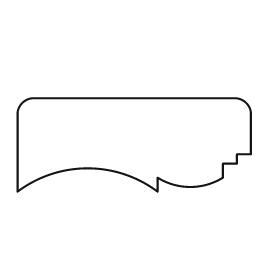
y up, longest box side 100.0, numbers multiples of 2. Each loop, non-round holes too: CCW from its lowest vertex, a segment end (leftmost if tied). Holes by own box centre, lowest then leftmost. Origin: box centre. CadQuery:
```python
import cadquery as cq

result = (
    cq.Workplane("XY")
    .moveTo(-50.0, -20.0)
    .threePointArc((-20.0, -10.0), (10.0, -20.0))
    .lineTo(10.0, -14.0)
    .threePointArc((24.0, -18.0), (38.0, -14.0))
    .lineTo(38.0, -8.0)
    .lineTo(44.0, -8.0)
    .lineTo(44.0, -4.0)
    .lineTo(50.0, -4.0)
    .lineTo(50.0, 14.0)
    .threePointArc((48.0, 18.0), (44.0, 20.0))
    .lineTo(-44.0, 20.0)
    .threePointArc((-48.0, 18.0), (-50.0, 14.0))
    .close()
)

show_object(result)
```